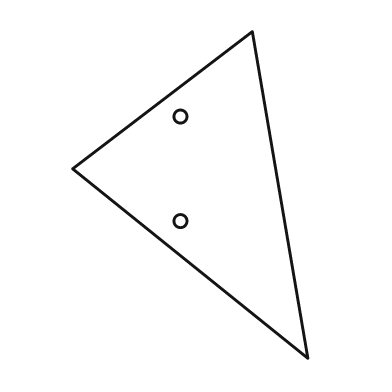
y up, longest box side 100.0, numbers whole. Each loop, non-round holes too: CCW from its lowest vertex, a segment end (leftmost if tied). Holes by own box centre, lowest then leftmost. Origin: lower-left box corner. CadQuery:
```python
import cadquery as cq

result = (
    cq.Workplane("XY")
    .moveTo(72.0, 0.0)
    .lineTo(55.0, 100.0)
    .lineTo(0.0, 58.0)
    .close()
    .moveTo(33.0, 42.0)
    .circle(2.0)
    .moveTo(33.0, 74.0)
    .circle(2.0)
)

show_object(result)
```